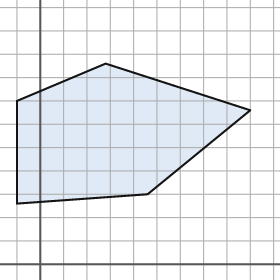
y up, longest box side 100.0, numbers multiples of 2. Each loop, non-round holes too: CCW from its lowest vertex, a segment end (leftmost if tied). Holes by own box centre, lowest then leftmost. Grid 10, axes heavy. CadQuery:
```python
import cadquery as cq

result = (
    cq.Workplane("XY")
    .moveTo(-10.0, 26.0)
    .lineTo(46.0, 30.0)
    .lineTo(90.0, 66.0)
    .lineTo(28.0, 86.0)
    .lineTo(-10.0, 70.0)
    .close()
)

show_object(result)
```